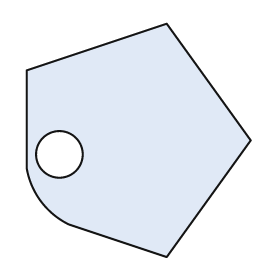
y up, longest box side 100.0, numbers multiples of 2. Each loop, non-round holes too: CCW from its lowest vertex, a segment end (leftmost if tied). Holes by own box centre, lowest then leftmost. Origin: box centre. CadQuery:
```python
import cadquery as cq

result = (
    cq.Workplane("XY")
    .moveTo(12.0, -50.0)
    .lineTo(48.0, 0.0)
    .lineTo(12.0, 50.0)
    .lineTo(-48.0, 30.0)
    .lineTo(-48.0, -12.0)
    .threePointArc((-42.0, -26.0), (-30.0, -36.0))
    .close()
    .moveTo(-34.0, -6.0)
    .circle(10.0)
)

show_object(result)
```